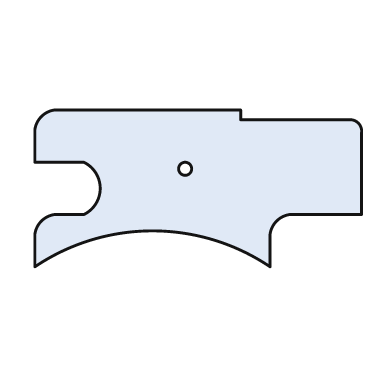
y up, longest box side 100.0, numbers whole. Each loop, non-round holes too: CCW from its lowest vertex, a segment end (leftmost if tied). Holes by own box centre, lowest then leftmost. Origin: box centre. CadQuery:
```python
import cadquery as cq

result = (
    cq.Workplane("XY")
    .moveTo(-50.0, -24.0)
    .threePointArc((-14.0, -13.0), (22.0, -24.0))
    .lineTo(22.0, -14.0)
    .threePointArc((24.0, -10.0), (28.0, -8.0))
    .lineTo(50.0, -8.0)
    .lineTo(50.0, 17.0)
    .threePointArc((49.0, 20.0), (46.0, 21.0))
    .lineTo(13.0, 21.0)
    .lineTo(13.0, 24.0)
    .lineTo(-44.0, 24.0)
    .threePointArc((-48.0, 22.0), (-50.0, 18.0))
    .lineTo(-50.0, 8.0)
    .lineTo(-35.0, 8.0)
    .threePointArc((-30.0, 0.0), (-35.0, -8.0))
    .lineTo(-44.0, -8.0)
    .threePointArc((-48.0, -10.0), (-50.0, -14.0))
    .close()
    .moveTo(-4.0, 6.0)
    .circle(2.0)
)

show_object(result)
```